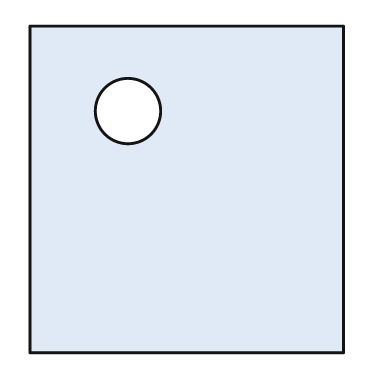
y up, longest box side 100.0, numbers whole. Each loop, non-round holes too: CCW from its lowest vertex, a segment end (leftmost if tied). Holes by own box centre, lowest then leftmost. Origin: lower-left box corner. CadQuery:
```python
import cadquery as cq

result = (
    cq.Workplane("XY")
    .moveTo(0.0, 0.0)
    .lineTo(96.0, 0.0)
    .lineTo(96.0, 100.0)
    .lineTo(0.0, 100.0)
    .close()
    .moveTo(30.0, 74.0)
    .circle(10.0)
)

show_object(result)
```